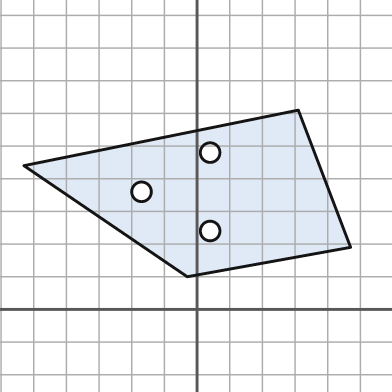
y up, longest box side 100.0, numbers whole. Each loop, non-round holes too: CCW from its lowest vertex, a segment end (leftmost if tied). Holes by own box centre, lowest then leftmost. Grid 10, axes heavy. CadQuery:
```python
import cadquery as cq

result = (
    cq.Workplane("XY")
    .moveTo(-3.0, 10.0)
    .lineTo(47.0, 19.0)
    .lineTo(31.0, 61.0)
    .lineTo(-53.0, 44.0)
    .close()
    .moveTo(4.0, 24.0)
    .circle(3.0)
    .moveTo(-17.0, 36.0)
    .circle(3.0)
    .moveTo(4.0, 48.0)
    .circle(3.0)
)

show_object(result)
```